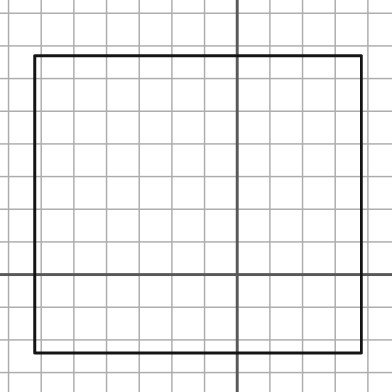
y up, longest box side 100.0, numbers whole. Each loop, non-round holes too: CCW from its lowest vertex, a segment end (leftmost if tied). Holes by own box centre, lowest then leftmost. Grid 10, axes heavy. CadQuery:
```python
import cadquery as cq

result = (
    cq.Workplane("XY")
    .moveTo(-62.0, -24.0)
    .lineTo(38.0, -24.0)
    .lineTo(38.0, 67.0)
    .lineTo(-62.0, 67.0)
    .close()
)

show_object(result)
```